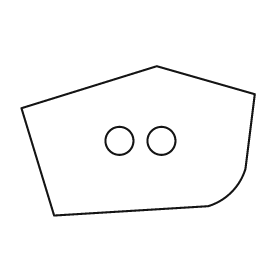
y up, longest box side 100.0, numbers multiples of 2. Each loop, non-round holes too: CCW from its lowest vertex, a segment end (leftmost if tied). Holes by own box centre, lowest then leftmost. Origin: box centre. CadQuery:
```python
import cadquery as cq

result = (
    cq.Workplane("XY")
    .moveTo(-36.0, -32.0)
    .lineTo(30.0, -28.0)
    .threePointArc((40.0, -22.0), (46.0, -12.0))
    .lineTo(50.0, 20.0)
    .lineTo(8.0, 32.0)
    .lineTo(-50.0, 14.0)
    .close()
    .moveTo(-8.0, 0.0)
    .circle(6.0)
    .moveTo(10.0, 0.0)
    .circle(6.0)
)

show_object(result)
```